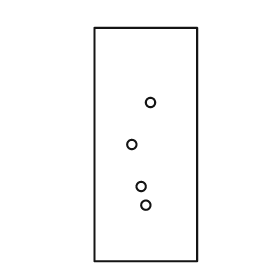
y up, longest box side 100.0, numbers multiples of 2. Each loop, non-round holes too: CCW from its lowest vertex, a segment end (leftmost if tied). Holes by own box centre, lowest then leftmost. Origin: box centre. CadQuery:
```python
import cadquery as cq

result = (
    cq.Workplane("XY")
    .moveTo(-22.0, -50.0)
    .lineTo(22.0, -50.0)
    .lineTo(22.0, 50.0)
    .lineTo(-22.0, 50.0)
    .close()
    .moveTo(0.0, -26.0)
    .circle(2.0)
    .moveTo(-2.0, -18.0)
    .circle(2.0)
    .moveTo(-6.0, 0.0)
    .circle(2.0)
    .moveTo(2.0, 18.0)
    .circle(2.0)
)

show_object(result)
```